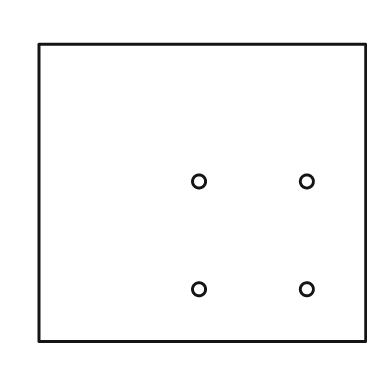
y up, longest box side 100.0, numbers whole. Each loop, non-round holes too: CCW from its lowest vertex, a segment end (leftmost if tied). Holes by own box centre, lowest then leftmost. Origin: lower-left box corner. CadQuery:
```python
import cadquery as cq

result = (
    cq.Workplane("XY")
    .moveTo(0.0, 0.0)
    .lineTo(100.0, 0.0)
    .lineTo(100.0, 91.0)
    .lineTo(0.0, 91.0)
    .close()
    .moveTo(49.0, 16.0)
    .circle(2.0)
    .moveTo(82.0, 16.0)
    .circle(2.0)
    .moveTo(49.0, 49.0)
    .circle(2.0)
    .moveTo(82.0, 49.0)
    .circle(2.0)
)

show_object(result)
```